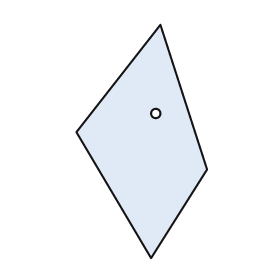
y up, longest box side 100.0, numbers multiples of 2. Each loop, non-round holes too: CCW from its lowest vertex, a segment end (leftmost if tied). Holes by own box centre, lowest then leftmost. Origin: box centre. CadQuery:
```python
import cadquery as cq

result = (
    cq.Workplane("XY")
    .moveTo(4.0, -50.0)
    .lineTo(28.0, -12.0)
    .lineTo(8.0, 50.0)
    .lineTo(-28.0, 4.0)
    .close()
    .moveTo(6.0, 12.0)
    .circle(2.0)
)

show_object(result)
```